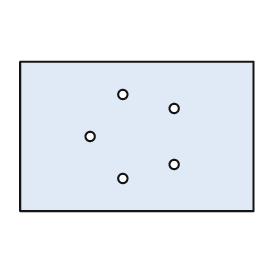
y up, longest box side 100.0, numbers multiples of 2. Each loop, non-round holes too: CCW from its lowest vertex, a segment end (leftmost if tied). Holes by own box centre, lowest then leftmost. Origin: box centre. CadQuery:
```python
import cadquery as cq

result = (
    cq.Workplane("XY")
    .moveTo(-50.0, -32.0)
    .lineTo(50.0, -32.0)
    .lineTo(50.0, 32.0)
    .lineTo(-50.0, 32.0)
    .close()
    .moveTo(-6.0, -18.0)
    .circle(2.0)
    .moveTo(16.0, -12.0)
    .circle(2.0)
    .moveTo(-20.0, 0.0)
    .circle(2.0)
    .moveTo(16.0, 12.0)
    .circle(2.0)
    .moveTo(-6.0, 18.0)
    .circle(2.0)
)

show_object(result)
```